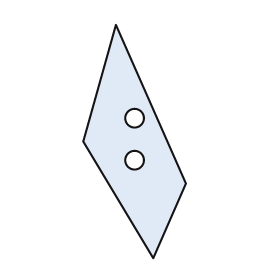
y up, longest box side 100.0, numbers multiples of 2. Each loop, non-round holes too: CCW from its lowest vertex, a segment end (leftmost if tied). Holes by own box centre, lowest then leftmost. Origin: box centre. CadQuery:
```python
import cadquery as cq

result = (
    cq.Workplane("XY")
    .moveTo(8.0, -50.0)
    .lineTo(22.0, -18.0)
    .lineTo(-8.0, 50.0)
    .lineTo(-22.0, 0.0)
    .close()
    .moveTo(0.0, -8.0)
    .circle(4.0)
    .moveTo(0.0, 10.0)
    .circle(4.0)
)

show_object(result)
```